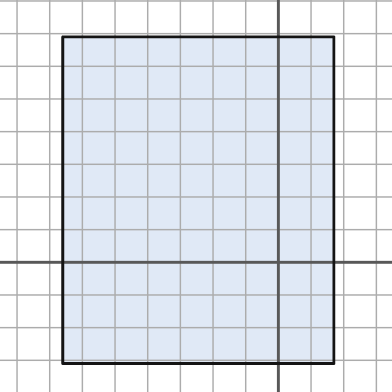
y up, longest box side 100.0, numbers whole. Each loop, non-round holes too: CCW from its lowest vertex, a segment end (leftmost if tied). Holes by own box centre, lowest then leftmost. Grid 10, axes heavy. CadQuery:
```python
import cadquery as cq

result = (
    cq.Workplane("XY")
    .moveTo(-66.0, -31.0)
    .lineTo(17.0, -31.0)
    .lineTo(17.0, 69.0)
    .lineTo(-66.0, 69.0)
    .close()
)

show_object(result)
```